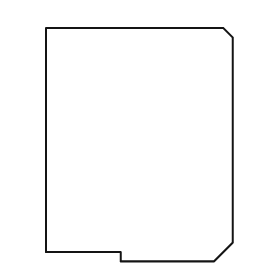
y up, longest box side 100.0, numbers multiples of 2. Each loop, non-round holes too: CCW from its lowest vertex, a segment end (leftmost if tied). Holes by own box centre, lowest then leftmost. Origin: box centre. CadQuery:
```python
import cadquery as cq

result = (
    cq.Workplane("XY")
    .moveTo(-8.0, -50.0)
    .lineTo(32.0, -50.0)
    .lineTo(40.0, -42.0)
    .lineTo(40.0, 46.0)
    .lineTo(36.0, 50.0)
    .lineTo(-40.0, 50.0)
    .lineTo(-40.0, -46.0)
    .lineTo(-8.0, -46.0)
    .close()
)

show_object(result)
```